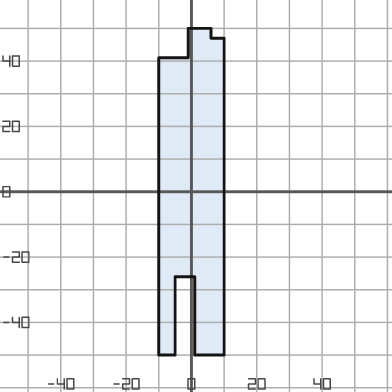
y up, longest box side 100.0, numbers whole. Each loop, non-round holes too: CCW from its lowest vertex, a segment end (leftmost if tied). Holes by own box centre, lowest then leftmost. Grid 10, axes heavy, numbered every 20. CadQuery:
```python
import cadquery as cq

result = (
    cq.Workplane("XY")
    .moveTo(-10.0, -50.0)
    .lineTo(-5.0, -50.0)
    .lineTo(-5.0, -26.0)
    .lineTo(1.0, -26.0)
    .lineTo(1.0, -50.0)
    .lineTo(10.0, -50.0)
    .lineTo(10.0, 47.0)
    .lineTo(6.0, 47.0)
    .lineTo(6.0, 50.0)
    .lineTo(-1.0, 50.0)
    .lineTo(-1.0, 41.0)
    .lineTo(-10.0, 41.0)
    .close()
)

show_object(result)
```